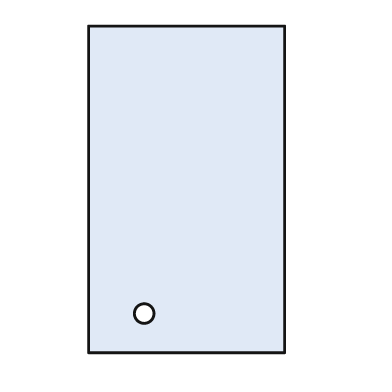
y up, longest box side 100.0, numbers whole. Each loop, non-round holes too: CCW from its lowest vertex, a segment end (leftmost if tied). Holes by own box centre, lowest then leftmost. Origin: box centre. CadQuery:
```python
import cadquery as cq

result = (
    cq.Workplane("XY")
    .moveTo(-30.0, -50.0)
    .lineTo(30.0, -50.0)
    .lineTo(30.0, 50.0)
    .lineTo(-30.0, 50.0)
    .close()
    .moveTo(-13.0, -38.0)
    .circle(3.0)
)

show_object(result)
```